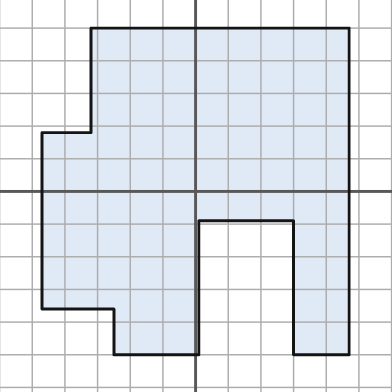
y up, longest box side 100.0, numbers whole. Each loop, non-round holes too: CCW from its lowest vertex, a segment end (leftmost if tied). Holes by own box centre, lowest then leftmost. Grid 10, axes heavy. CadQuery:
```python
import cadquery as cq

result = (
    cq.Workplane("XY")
    .moveTo(-25.0, -50.0)
    .lineTo(1.0, -50.0)
    .lineTo(1.0, -9.0)
    .lineTo(30.0, -9.0)
    .lineTo(30.0, -50.0)
    .lineTo(47.0, -50.0)
    .lineTo(47.0, 50.0)
    .lineTo(-32.0, 50.0)
    .lineTo(-32.0, 18.0)
    .lineTo(-47.0, 18.0)
    .lineTo(-47.0, -36.0)
    .lineTo(-25.0, -36.0)
    .close()
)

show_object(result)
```